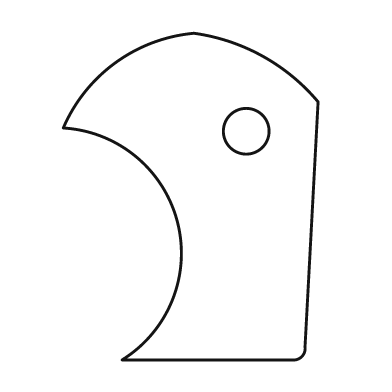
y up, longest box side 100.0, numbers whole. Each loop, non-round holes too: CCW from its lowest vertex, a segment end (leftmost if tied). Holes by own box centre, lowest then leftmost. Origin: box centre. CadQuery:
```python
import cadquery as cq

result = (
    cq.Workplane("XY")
    .moveTo(-21.0, -50.0)
    .lineTo(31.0, -50.0)
    .threePointArc((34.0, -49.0), (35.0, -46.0))
    .lineTo(39.0, 29.0)
    .threePointArc((22.0, 43.0), (1.0, 50.0))
    .threePointArc((-23.0, 41.0), (-39.0, 21.0))
    .threePointArc((-4.0, -8.0), (-21.0, -50.0))
    .close()
    .moveTo(17.0, 20.0)
    .circle(7.0)
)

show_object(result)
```